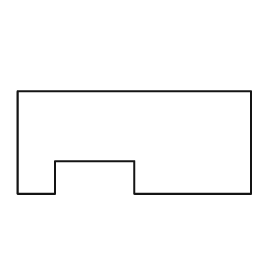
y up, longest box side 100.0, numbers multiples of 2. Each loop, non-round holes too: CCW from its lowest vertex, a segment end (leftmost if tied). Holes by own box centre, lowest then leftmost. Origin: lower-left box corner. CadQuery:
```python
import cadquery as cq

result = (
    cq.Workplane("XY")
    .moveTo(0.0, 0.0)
    .lineTo(16.0, 0.0)
    .lineTo(16.0, 14.0)
    .lineTo(50.0, 14.0)
    .lineTo(50.0, 0.0)
    .lineTo(100.0, 0.0)
    .lineTo(100.0, 44.0)
    .lineTo(0.0, 44.0)
    .close()
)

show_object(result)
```